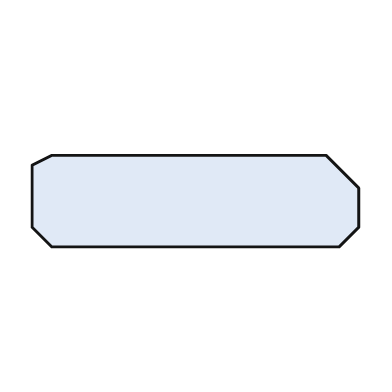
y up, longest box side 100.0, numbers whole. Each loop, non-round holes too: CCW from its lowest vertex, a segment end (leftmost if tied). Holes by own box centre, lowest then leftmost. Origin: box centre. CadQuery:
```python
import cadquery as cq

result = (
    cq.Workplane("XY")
    .moveTo(-44.0, -14.0)
    .lineTo(44.0, -14.0)
    .lineTo(50.0, -8.0)
    .lineTo(50.0, 4.0)
    .lineTo(40.0, 14.0)
    .lineTo(-44.0, 14.0)
    .lineTo(-50.0, 11.0)
    .lineTo(-50.0, -8.0)
    .close()
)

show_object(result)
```